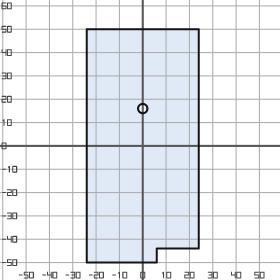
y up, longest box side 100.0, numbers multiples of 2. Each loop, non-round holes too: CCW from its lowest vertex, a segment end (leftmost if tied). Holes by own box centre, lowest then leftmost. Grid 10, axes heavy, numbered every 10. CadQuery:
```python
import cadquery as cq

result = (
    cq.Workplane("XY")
    .moveTo(-24.0, -50.0)
    .lineTo(6.0, -50.0)
    .lineTo(6.0, -44.0)
    .lineTo(24.0, -44.0)
    .lineTo(24.0, 50.0)
    .lineTo(-24.0, 50.0)
    .close()
    .moveTo(0.0, 16.0)
    .circle(2.0)
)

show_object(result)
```